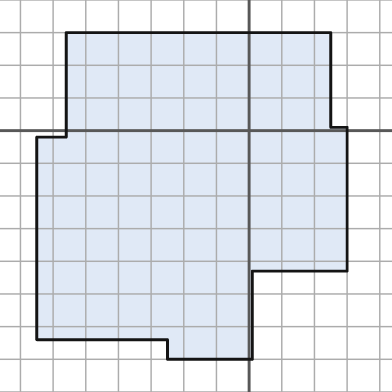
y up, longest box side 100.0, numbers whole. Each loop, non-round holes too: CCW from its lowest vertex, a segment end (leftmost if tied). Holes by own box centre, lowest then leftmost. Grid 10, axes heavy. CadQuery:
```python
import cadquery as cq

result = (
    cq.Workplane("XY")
    .moveTo(-25.0, -70.0)
    .lineTo(1.0, -70.0)
    .lineTo(1.0, -43.0)
    .lineTo(30.0, -43.0)
    .lineTo(30.0, 1.0)
    .lineTo(25.0, 1.0)
    .lineTo(25.0, 30.0)
    .lineTo(-56.0, 30.0)
    .lineTo(-56.0, -2.0)
    .lineTo(-65.0, -2.0)
    .lineTo(-65.0, -64.0)
    .lineTo(-25.0, -64.0)
    .close()
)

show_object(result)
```